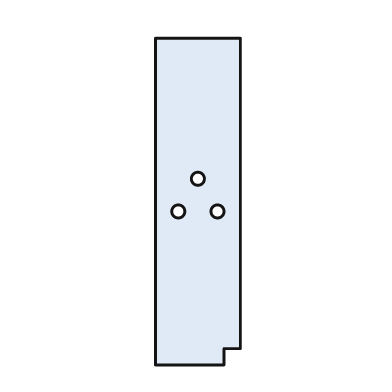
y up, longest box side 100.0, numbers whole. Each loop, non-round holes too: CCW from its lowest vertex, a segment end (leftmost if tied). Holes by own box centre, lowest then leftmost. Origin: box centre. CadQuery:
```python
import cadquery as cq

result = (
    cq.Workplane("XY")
    .moveTo(-13.0, -50.0)
    .lineTo(8.0, -50.0)
    .lineTo(8.0, -45.0)
    .lineTo(13.0, -45.0)
    .lineTo(13.0, 50.0)
    .lineTo(-13.0, 50.0)
    .close()
    .moveTo(-6.0, -3.0)
    .circle(2.0)
    .moveTo(6.0, -3.0)
    .circle(2.0)
    .moveTo(0.0, 7.0)
    .circle(2.0)
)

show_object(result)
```